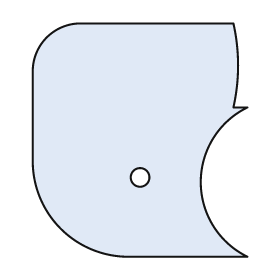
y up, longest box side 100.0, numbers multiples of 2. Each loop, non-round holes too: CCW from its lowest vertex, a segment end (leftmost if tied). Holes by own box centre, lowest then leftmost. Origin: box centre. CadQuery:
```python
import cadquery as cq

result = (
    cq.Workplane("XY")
    .moveTo(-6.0, -50.0)
    .lineTo(46.0, -50.0)
    .threePointArc((26.0, -18.0), (46.0, 14.0))
    .lineTo(40.0, 14.0)
    .threePointArc((42.0, 32.0), (40.0, 50.0))
    .lineTo(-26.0, 50.0)
    .threePointArc((-40.0, 44.0), (-46.0, 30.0))
    .lineTo(-46.0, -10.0)
    .threePointArc((-34.0, -38.0), (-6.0, -50.0))
    .close()
    .moveTo(0.0, -16.0)
    .circle(4.0)
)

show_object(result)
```